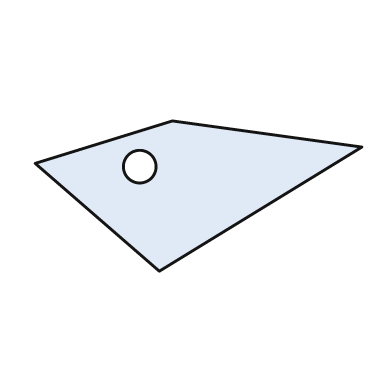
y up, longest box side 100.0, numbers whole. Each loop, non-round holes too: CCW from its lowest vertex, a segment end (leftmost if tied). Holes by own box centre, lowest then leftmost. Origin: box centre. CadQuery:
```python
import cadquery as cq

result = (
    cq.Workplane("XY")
    .moveTo(-12.0, -23.0)
    .lineTo(50.0, 15.0)
    .lineTo(-8.0, 23.0)
    .lineTo(-50.0, 10.0)
    .close()
    .moveTo(-18.0, 9.0)
    .circle(5.0)
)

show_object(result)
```